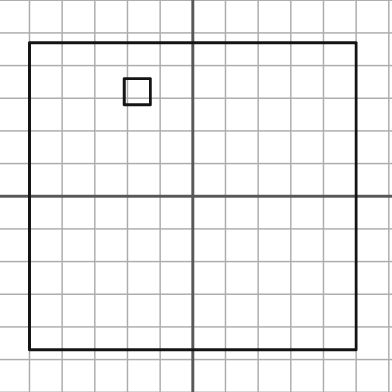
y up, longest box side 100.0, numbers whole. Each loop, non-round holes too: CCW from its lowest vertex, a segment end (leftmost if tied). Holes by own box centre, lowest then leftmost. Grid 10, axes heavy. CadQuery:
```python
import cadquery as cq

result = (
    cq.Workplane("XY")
    .moveTo(-50.0, -47.0)
    .lineTo(50.0, -47.0)
    .lineTo(50.0, 47.0)
    .lineTo(-50.0, 47.0)
    .close()
    .moveTo(-21.0, 28.0)
    .lineTo(-13.0, 28.0)
    .lineTo(-13.0, 36.0)
    .lineTo(-21.0, 36.0)
    .close()
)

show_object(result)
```